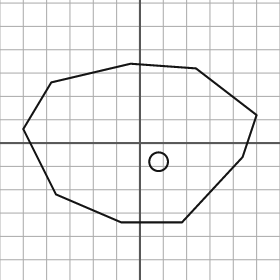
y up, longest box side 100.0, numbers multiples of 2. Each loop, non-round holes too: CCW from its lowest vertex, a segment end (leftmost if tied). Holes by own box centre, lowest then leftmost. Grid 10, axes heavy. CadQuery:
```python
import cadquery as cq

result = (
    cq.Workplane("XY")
    .moveTo(-8.0, -34.0)
    .lineTo(18.0, -34.0)
    .lineTo(44.0, -6.0)
    .lineTo(50.0, 12.0)
    .lineTo(24.0, 32.0)
    .lineTo(-4.0, 34.0)
    .lineTo(-38.0, 26.0)
    .lineTo(-50.0, 6.0)
    .lineTo(-36.0, -22.0)
    .close()
    .moveTo(8.0, -8.0)
    .circle(4.0)
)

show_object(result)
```